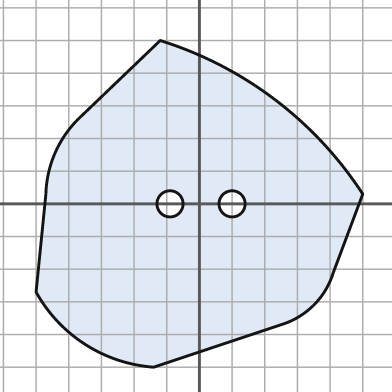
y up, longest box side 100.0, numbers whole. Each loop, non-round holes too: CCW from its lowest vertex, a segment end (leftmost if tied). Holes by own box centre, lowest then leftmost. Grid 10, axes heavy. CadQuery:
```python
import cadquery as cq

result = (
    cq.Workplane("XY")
    .moveTo(-14.0, -50.0)
    .lineTo(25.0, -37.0)
    .threePointArc((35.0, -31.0), (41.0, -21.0))
    .lineTo(50.0, 3.0)
    .threePointArc((23.0, 32.0), (-12.0, 50.0))
    .lineTo(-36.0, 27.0)
    .threePointArc((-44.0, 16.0), (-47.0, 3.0))
    .lineTo(-50.0, -27.0)
    .threePointArc((-35.0, -43.0), (-14.0, -50.0))
    .close()
    .moveTo(-9.0, 0.0)
    .circle(4.0)
    .moveTo(10.0, 0.0)
    .circle(4.0)
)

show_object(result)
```